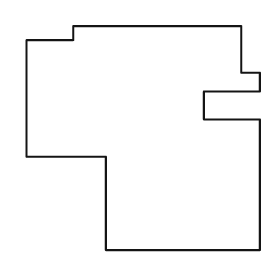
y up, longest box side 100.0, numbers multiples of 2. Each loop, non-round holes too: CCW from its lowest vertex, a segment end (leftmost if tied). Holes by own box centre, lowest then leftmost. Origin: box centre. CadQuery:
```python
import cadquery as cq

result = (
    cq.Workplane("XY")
    .moveTo(-16.0, -48.0)
    .lineTo(50.0, -48.0)
    .lineTo(50.0, 8.0)
    .lineTo(26.0, 8.0)
    .lineTo(26.0, 20.0)
    .lineTo(50.0, 20.0)
    .lineTo(50.0, 28.0)
    .lineTo(42.0, 28.0)
    .lineTo(42.0, 48.0)
    .lineTo(-30.0, 48.0)
    .lineTo(-30.0, 42.0)
    .lineTo(-50.0, 42.0)
    .lineTo(-50.0, -8.0)
    .lineTo(-16.0, -8.0)
    .close()
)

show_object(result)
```